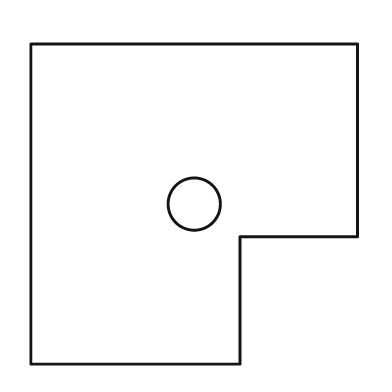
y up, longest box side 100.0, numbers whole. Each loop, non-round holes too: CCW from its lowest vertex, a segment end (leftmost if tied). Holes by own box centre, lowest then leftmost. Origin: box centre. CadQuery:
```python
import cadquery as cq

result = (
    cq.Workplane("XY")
    .moveTo(-50.0, -49.0)
    .lineTo(14.0, -49.0)
    .lineTo(14.0, -10.0)
    .lineTo(50.0, -10.0)
    .lineTo(50.0, 49.0)
    .lineTo(-50.0, 49.0)
    .close()
    .moveTo(0.0, 0.0)
    .circle(8.0)
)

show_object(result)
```